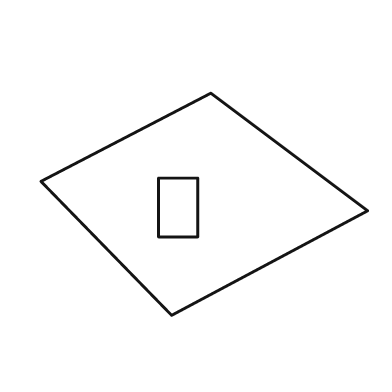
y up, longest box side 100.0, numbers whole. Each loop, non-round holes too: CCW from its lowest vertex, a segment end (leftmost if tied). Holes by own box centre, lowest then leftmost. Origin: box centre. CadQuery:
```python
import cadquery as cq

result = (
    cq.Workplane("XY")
    .moveTo(-10.0, -34.0)
    .lineTo(50.0, -2.0)
    .lineTo(2.0, 34.0)
    .lineTo(-50.0, 7.0)
    .close()
    .moveTo(-14.0, -10.0)
    .lineTo(-2.0, -10.0)
    .lineTo(-2.0, 8.0)
    .lineTo(-14.0, 8.0)
    .close()
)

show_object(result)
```